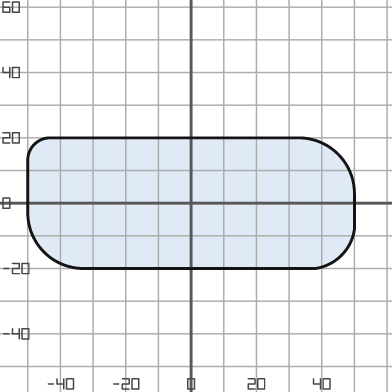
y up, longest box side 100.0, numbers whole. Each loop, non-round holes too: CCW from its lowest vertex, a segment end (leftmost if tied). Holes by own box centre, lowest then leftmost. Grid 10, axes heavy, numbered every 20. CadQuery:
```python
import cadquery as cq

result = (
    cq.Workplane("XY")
    .moveTo(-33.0, -20.0)
    .lineTo(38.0, -20.0)
    .threePointArc((46.0, -16.0), (50.0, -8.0))
    .lineTo(50.0, 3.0)
    .threePointArc((45.0, 15.0), (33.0, 20.0))
    .lineTo(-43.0, 20.0)
    .threePointArc((-48.0, 18.0), (-50.0, 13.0))
    .lineTo(-50.0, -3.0)
    .threePointArc((-45.0, -15.0), (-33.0, -20.0))
    .close()
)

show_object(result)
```